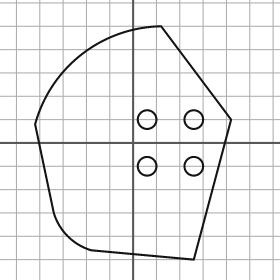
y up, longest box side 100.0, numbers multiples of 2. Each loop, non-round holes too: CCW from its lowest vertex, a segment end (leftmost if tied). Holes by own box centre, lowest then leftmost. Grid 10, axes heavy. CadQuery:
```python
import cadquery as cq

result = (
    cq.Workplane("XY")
    .moveTo(26.0, -50.0)
    .lineTo(42.0, 10.0)
    .lineTo(12.0, 50.0)
    .threePointArc((-22.0, 38.0), (-42.0, 8.0))
    .lineTo(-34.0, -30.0)
    .threePointArc((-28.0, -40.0), (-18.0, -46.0))
    .close()
    .moveTo(6.0, -10.0)
    .circle(4.0)
    .moveTo(26.0, -10.0)
    .circle(4.0)
    .moveTo(6.0, 10.0)
    .circle(4.0)
    .moveTo(26.0, 10.0)
    .circle(4.0)
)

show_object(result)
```